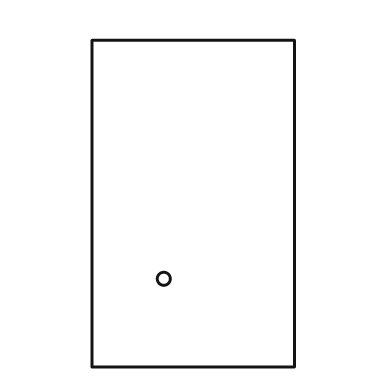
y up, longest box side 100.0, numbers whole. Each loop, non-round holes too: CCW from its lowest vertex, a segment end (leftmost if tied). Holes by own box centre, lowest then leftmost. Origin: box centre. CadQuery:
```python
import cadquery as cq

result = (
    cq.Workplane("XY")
    .moveTo(-31.0, -50.0)
    .lineTo(31.0, -50.0)
    .lineTo(31.0, 50.0)
    .lineTo(-31.0, 50.0)
    .close()
    .moveTo(-9.0, -23.0)
    .circle(2.0)
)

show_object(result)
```